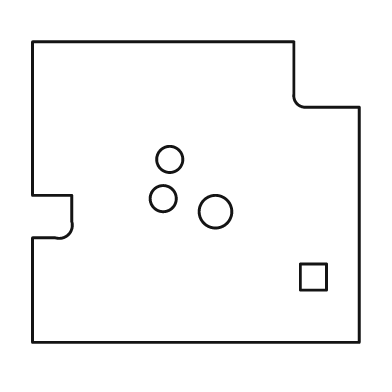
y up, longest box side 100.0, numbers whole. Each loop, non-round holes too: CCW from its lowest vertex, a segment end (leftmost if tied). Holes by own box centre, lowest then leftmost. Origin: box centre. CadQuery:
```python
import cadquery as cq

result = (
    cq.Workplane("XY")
    .moveTo(-50.0, -46.0)
    .lineTo(50.0, -46.0)
    .lineTo(50.0, 26.0)
    .lineTo(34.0, 26.0)
    .threePointArc((31.0, 27.0), (30.0, 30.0))
    .lineTo(30.0, 46.0)
    .lineTo(-50.0, 46.0)
    .lineTo(-50.0, -1.0)
    .lineTo(-38.0, -1.0)
    .lineTo(-38.0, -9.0)
    .threePointArc((-39.0, -13.0), (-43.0, -14.0))
    .lineTo(-50.0, -14.0)
    .close()
    .moveTo(32.0, -30.0)
    .lineTo(40.0, -30.0)
    .lineTo(40.0, -22.0)
    .lineTo(32.0, -22.0)
    .close()
    .moveTo(6.0, -6.0)
    .circle(5.0)
    .moveTo(-10.0, -2.0)
    .circle(4.0)
    .moveTo(-8.0, 10.0)
    .circle(4.0)
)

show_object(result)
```